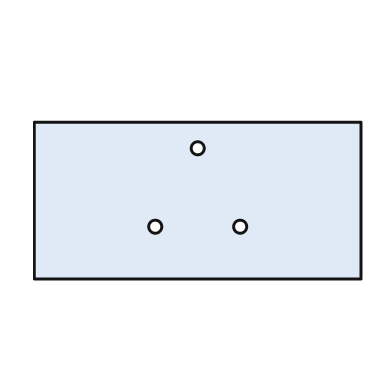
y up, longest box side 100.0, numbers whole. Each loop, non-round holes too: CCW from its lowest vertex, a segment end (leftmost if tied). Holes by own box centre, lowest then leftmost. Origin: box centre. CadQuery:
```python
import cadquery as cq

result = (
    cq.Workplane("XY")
    .moveTo(-50.0, -24.0)
    .lineTo(50.0, -24.0)
    .lineTo(50.0, 24.0)
    .lineTo(-50.0, 24.0)
    .close()
    .moveTo(-13.0, -8.0)
    .circle(2.0)
    .moveTo(13.0, -8.0)
    .circle(2.0)
    .moveTo(0.0, 16.0)
    .circle(2.0)
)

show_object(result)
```